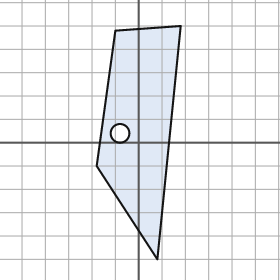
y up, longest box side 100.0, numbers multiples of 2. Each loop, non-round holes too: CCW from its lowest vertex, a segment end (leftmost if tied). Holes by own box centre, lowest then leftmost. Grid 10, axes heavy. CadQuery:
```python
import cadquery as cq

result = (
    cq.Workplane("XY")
    .moveTo(8.0, -50.0)
    .lineTo(18.0, 50.0)
    .lineTo(-10.0, 48.0)
    .lineTo(-18.0, -10.0)
    .close()
    .moveTo(-8.0, 4.0)
    .circle(4.0)
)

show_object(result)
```